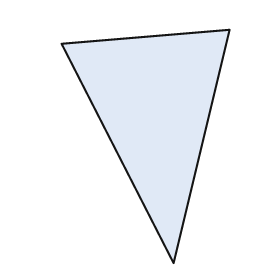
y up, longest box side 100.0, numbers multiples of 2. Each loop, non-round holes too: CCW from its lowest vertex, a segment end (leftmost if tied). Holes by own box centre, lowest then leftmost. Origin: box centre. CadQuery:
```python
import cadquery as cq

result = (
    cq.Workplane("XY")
    .moveTo(12.0, -50.0)
    .lineTo(36.0, 50.0)
    .lineTo(-36.0, 44.0)
    .close()
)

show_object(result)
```